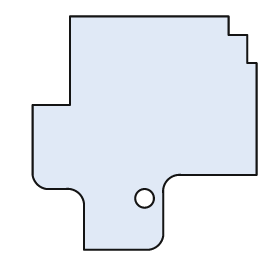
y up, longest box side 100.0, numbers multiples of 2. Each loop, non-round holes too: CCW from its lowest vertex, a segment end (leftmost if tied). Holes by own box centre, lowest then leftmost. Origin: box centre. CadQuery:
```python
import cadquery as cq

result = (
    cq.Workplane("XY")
    .moveTo(-26.0, -50.0)
    .lineTo(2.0, -50.0)
    .threePointArc((6.0, -48.0), (8.0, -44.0))
    .lineTo(8.0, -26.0)
    .threePointArc((10.0, -20.0), (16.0, -18.0))
    .lineTo(48.0, -18.0)
    .lineTo(48.0, 30.0)
    .lineTo(44.0, 30.0)
    .lineTo(44.0, 42.0)
    .lineTo(36.0, 42.0)
    .lineTo(36.0, 50.0)
    .lineTo(-32.0, 50.0)
    .lineTo(-32.0, 12.0)
    .lineTo(-48.0, 12.0)
    .lineTo(-48.0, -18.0)
    .threePointArc((-46.0, -22.0), (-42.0, -24.0))
    .lineTo(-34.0, -24.0)
    .threePointArc((-28.0, -26.0), (-26.0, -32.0))
    .close()
    .moveTo(0.0, -28.0)
    .circle(4.0)
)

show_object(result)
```